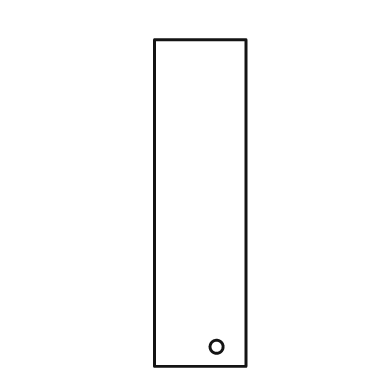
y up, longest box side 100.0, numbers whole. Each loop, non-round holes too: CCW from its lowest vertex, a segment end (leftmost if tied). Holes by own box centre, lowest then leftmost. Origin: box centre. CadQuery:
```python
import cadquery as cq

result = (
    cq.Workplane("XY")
    .moveTo(-14.0, -50.0)
    .lineTo(14.0, -50.0)
    .lineTo(14.0, 50.0)
    .lineTo(-14.0, 50.0)
    .close()
    .moveTo(5.0, -44.0)
    .circle(2.0)
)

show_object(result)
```